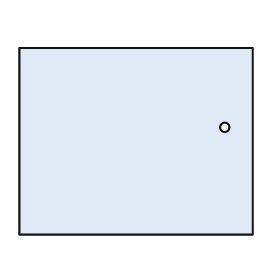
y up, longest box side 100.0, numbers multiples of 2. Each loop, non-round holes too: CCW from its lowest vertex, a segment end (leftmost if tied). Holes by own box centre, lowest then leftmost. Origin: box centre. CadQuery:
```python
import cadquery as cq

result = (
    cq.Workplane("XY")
    .moveTo(-50.0, -40.0)
    .lineTo(50.0, -40.0)
    .lineTo(50.0, 40.0)
    .lineTo(-50.0, 40.0)
    .close()
    .moveTo(38.0, 6.0)
    .circle(2.0)
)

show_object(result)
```